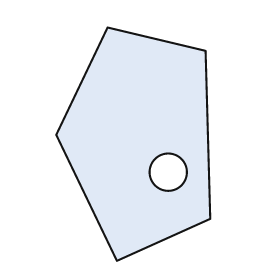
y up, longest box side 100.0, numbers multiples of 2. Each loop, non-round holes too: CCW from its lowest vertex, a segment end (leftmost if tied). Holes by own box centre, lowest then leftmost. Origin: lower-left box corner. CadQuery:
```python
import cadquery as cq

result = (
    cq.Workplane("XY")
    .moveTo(26.0, 0.0)
    .lineTo(66.0, 18.0)
    .lineTo(64.0, 90.0)
    .lineTo(22.0, 100.0)
    .lineTo(0.0, 54.0)
    .close()
    .moveTo(48.0, 38.0)
    .circle(8.0)
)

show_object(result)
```